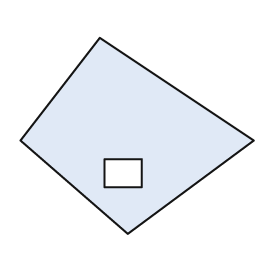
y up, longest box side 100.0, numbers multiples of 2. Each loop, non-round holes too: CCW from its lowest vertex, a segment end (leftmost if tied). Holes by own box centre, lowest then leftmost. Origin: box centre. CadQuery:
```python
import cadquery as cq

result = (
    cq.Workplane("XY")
    .moveTo(-4.0, -42.0)
    .lineTo(50.0, -2.0)
    .lineTo(-16.0, 42.0)
    .lineTo(-50.0, -2.0)
    .close()
    .moveTo(-14.0, -22.0)
    .lineTo(2.0, -22.0)
    .lineTo(2.0, -10.0)
    .lineTo(-14.0, -10.0)
    .close()
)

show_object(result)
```